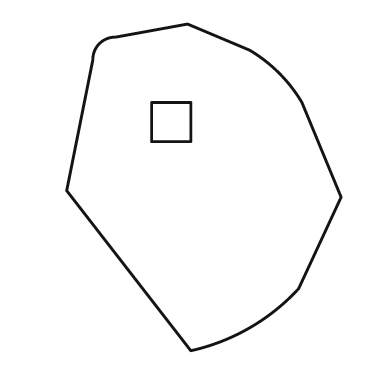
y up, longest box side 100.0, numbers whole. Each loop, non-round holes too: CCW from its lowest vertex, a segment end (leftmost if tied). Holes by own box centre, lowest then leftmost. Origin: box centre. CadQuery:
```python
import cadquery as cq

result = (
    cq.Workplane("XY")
    .moveTo(-4.0, -50.0)
    .threePointArc((14.0, -43.0), (29.0, -31.0))
    .lineTo(42.0, -3.0)
    .lineTo(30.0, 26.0)
    .threePointArc((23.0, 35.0), (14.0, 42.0))
    .lineTo(-5.0, 50.0)
    .lineTo(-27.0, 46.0)
    .threePointArc((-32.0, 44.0), (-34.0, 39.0))
    .lineTo(-42.0, -1.0)
    .close()
    .moveTo(-16.0, 14.0)
    .lineTo(-4.0, 14.0)
    .lineTo(-4.0, 26.0)
    .lineTo(-16.0, 26.0)
    .close()
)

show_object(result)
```